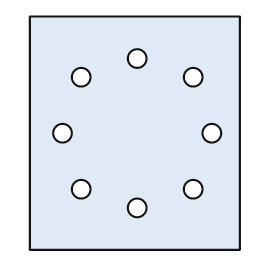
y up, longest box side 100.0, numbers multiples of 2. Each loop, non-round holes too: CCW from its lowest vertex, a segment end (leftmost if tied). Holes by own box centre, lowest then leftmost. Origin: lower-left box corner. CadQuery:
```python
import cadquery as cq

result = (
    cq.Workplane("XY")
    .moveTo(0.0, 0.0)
    .lineTo(90.0, 0.0)
    .lineTo(90.0, 100.0)
    .lineTo(0.0, 100.0)
    .close()
    .moveTo(46.0, 18.0)
    .circle(4.0)
    .moveTo(22.0, 26.0)
    .circle(4.0)
    .moveTo(70.0, 26.0)
    .circle(4.0)
    .moveTo(14.0, 50.0)
    .circle(4.0)
    .moveTo(78.0, 50.0)
    .circle(4.0)
    .moveTo(22.0, 74.0)
    .circle(4.0)
    .moveTo(70.0, 74.0)
    .circle(4.0)
    .moveTo(46.0, 82.0)
    .circle(4.0)
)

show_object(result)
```